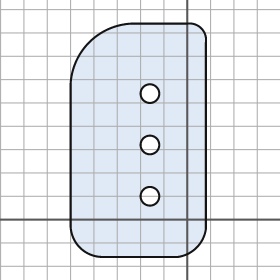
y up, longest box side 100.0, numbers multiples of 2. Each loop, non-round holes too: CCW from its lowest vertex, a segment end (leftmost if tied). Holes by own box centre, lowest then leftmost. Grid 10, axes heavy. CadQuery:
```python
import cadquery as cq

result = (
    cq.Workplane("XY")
    .moveTo(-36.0, -16.0)
    .lineTo(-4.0, -16.0)
    .threePointArc((4.0, -12.0), (8.0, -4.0))
    .lineTo(8.0, 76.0)
    .threePointArc((6.0, 82.0), (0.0, 84.0))
    .lineTo(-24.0, 84.0)
    .threePointArc((-42.0, 76.0), (-50.0, 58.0))
    .lineTo(-50.0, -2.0)
    .threePointArc((-46.0, -12.0), (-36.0, -16.0))
    .close()
    .moveTo(-16.0, 10.0)
    .circle(4.0)
    .moveTo(-16.0, 32.0)
    .circle(4.0)
    .moveTo(-16.0, 54.0)
    .circle(4.0)
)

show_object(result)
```